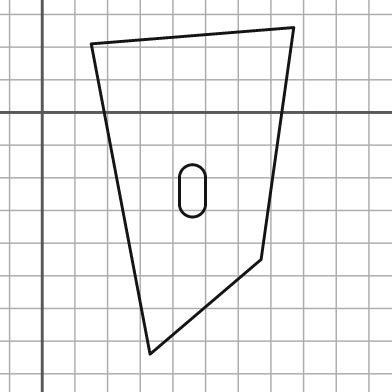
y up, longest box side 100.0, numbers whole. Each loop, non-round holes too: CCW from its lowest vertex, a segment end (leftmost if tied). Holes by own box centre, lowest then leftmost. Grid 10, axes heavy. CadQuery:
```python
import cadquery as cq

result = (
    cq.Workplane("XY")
    .moveTo(33.0, -74.0)
    .lineTo(67.0, -45.0)
    .lineTo(77.0, 26.0)
    .lineTo(15.0, 21.0)
    .close()
    .moveTo(42.0, -28.0)
    .threePointArc((46.0, -32.0), (50.0, -28.0))
    .lineTo(50.0, -20.0)
    .threePointArc((46.0, -16.0), (42.0, -20.0))
    .close()
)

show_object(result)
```